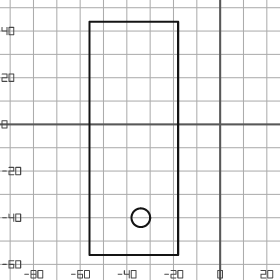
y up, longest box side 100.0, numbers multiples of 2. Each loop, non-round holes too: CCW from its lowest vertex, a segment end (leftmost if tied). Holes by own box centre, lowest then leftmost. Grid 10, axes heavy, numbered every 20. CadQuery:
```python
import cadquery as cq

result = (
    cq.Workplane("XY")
    .moveTo(-56.0, -56.0)
    .lineTo(-18.0, -56.0)
    .lineTo(-18.0, 44.0)
    .lineTo(-56.0, 44.0)
    .close()
    .moveTo(-34.0, -40.0)
    .circle(4.0)
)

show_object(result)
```